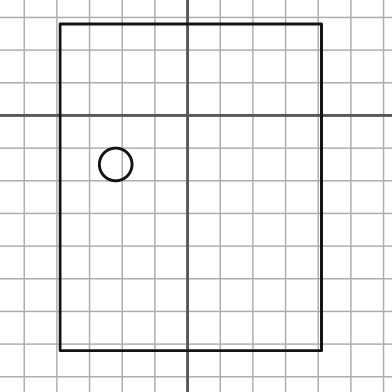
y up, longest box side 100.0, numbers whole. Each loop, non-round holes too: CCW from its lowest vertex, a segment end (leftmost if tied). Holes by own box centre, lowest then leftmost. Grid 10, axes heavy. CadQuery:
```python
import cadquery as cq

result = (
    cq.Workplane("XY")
    .moveTo(-39.0, -72.0)
    .lineTo(41.0, -72.0)
    .lineTo(41.0, 28.0)
    .lineTo(-39.0, 28.0)
    .close()
    .moveTo(-22.0, -15.0)
    .circle(5.0)
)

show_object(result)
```